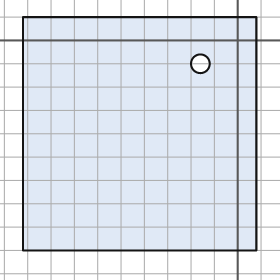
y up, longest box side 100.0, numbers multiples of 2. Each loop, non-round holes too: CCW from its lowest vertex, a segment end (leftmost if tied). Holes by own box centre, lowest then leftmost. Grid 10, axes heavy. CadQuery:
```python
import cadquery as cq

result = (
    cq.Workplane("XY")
    .moveTo(-92.0, -90.0)
    .lineTo(8.0, -90.0)
    .lineTo(8.0, 10.0)
    .lineTo(-92.0, 10.0)
    .close()
    .moveTo(-16.0, -10.0)
    .circle(4.0)
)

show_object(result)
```